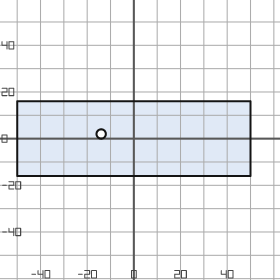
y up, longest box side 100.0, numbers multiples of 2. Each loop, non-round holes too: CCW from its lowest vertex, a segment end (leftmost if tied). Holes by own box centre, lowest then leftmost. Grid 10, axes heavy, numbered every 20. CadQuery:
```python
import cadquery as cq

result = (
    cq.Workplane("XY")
    .moveTo(-50.0, -16.0)
    .lineTo(50.0, -16.0)
    .lineTo(50.0, 16.0)
    .lineTo(-50.0, 16.0)
    .close()
    .moveTo(-14.0, 2.0)
    .circle(2.0)
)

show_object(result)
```